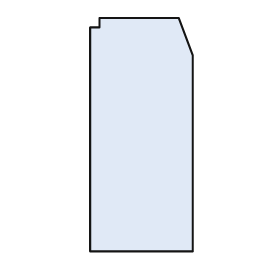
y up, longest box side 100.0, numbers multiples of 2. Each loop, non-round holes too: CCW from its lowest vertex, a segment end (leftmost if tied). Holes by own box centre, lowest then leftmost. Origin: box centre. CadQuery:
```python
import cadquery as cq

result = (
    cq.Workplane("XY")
    .moveTo(-22.0, -50.0)
    .lineTo(22.0, -50.0)
    .lineTo(22.0, 34.0)
    .lineTo(16.0, 50.0)
    .lineTo(-18.0, 50.0)
    .lineTo(-18.0, 46.0)
    .lineTo(-22.0, 46.0)
    .close()
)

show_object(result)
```